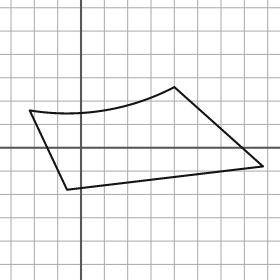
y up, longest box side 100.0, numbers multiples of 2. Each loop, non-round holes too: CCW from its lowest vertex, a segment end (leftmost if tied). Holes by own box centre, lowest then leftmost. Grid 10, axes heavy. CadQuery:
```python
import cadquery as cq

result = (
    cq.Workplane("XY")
    .moveTo(-6.0, -18.0)
    .lineTo(78.0, -8.0)
    .lineTo(40.0, 26.0)
    .threePointArc((10.0, 16.0), (-22.0, 16.0))
    .close()
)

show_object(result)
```